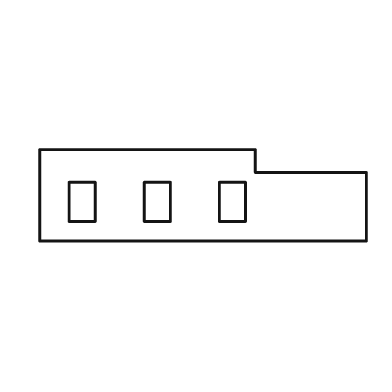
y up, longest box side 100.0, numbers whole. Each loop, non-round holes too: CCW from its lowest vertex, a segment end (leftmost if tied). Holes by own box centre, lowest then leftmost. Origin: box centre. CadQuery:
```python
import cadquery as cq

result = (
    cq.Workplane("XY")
    .moveTo(-50.0, -14.0)
    .lineTo(50.0, -14.0)
    .lineTo(50.0, 7.0)
    .lineTo(16.0, 7.0)
    .lineTo(16.0, 14.0)
    .lineTo(-50.0, 14.0)
    .close()
    .moveTo(-41.0, -8.0)
    .lineTo(-33.0, -8.0)
    .lineTo(-33.0, 4.0)
    .lineTo(-41.0, 4.0)
    .close()
    .moveTo(-18.0, -8.0)
    .lineTo(-10.0, -8.0)
    .lineTo(-10.0, 4.0)
    .lineTo(-18.0, 4.0)
    .close()
    .moveTo(5.0, -8.0)
    .lineTo(13.0, -8.0)
    .lineTo(13.0, 4.0)
    .lineTo(5.0, 4.0)
    .close()
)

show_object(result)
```